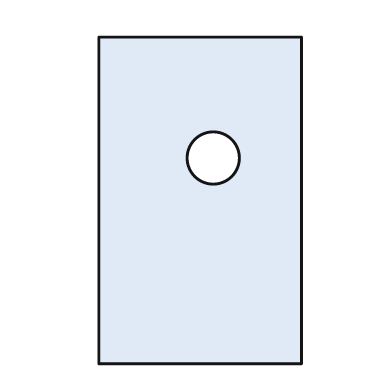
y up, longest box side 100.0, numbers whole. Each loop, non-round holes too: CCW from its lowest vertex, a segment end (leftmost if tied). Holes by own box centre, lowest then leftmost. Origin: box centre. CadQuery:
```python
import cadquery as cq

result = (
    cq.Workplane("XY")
    .moveTo(-31.0, -50.0)
    .lineTo(31.0, -50.0)
    .lineTo(31.0, 50.0)
    .lineTo(-31.0, 50.0)
    .close()
    .moveTo(4.0, 13.0)
    .circle(8.0)
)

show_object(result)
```